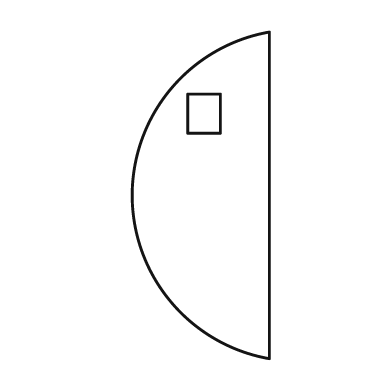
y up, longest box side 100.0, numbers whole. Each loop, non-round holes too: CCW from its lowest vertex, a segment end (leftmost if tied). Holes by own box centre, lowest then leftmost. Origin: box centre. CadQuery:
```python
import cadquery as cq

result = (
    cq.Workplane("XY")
    .moveTo(21.0, -50.0)
    .lineTo(21.0, 50.0)
    .threePointArc((-21.0, 0.0), (21.0, -50.0))
    .close()
    .moveTo(-4.0, 19.0)
    .lineTo(6.0, 19.0)
    .lineTo(6.0, 31.0)
    .lineTo(-4.0, 31.0)
    .close()
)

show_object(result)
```